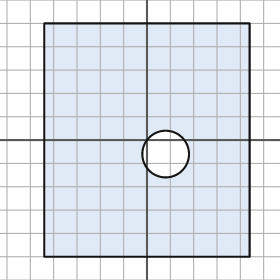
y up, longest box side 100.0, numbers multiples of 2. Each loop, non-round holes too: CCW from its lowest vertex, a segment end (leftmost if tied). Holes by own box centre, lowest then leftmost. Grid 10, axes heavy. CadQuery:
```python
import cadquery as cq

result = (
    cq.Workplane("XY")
    .moveTo(-44.0, -50.0)
    .lineTo(44.0, -50.0)
    .lineTo(44.0, 50.0)
    .lineTo(-44.0, 50.0)
    .close()
    .moveTo(8.0, -6.0)
    .circle(10.0)
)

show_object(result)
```